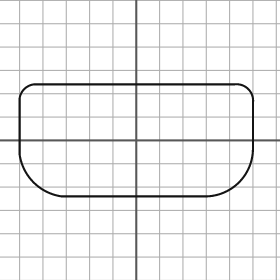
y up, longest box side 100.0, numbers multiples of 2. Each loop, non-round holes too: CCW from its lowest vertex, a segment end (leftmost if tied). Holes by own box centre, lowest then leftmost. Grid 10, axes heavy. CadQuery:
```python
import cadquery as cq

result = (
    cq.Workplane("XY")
    .moveTo(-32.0, -24.0)
    .lineTo(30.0, -24.0)
    .threePointArc((44.0, -18.0), (50.0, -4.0))
    .lineTo(50.0, 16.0)
    .threePointArc((48.0, 22.0), (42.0, 24.0))
    .lineTo(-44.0, 24.0)
    .threePointArc((-48.0, 22.0), (-50.0, 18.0))
    .lineTo(-50.0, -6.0)
    .threePointArc((-44.0, -18.0), (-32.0, -24.0))
    .close()
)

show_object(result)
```